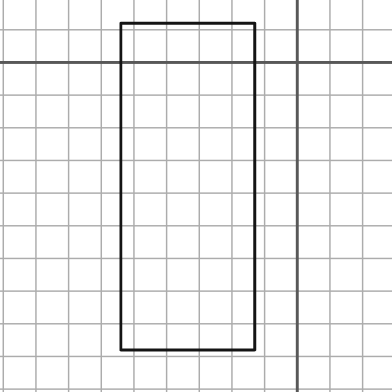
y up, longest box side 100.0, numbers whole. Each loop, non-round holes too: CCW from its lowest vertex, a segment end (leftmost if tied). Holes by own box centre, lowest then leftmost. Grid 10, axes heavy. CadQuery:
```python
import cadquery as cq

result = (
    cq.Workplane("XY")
    .moveTo(-54.0, -88.0)
    .lineTo(-13.0, -88.0)
    .lineTo(-13.0, 12.0)
    .lineTo(-54.0, 12.0)
    .close()
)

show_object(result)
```